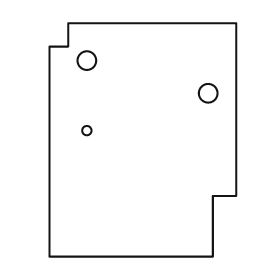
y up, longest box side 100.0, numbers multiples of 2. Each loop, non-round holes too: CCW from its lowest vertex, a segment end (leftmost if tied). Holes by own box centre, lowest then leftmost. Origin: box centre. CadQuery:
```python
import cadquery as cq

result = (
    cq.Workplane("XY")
    .moveTo(-40.0, -50.0)
    .lineTo(30.0, -50.0)
    .lineTo(30.0, -24.0)
    .lineTo(40.0, -24.0)
    .lineTo(40.0, 50.0)
    .lineTo(-32.0, 50.0)
    .lineTo(-32.0, 40.0)
    .lineTo(-40.0, 40.0)
    .close()
    .moveTo(-24.0, 4.0)
    .circle(2.0)
    .moveTo(28.0, 20.0)
    .circle(4.0)
    .moveTo(-24.0, 34.0)
    .circle(4.0)
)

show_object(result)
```